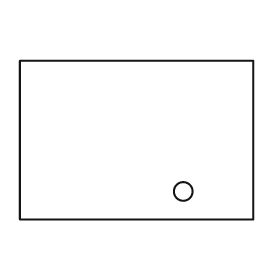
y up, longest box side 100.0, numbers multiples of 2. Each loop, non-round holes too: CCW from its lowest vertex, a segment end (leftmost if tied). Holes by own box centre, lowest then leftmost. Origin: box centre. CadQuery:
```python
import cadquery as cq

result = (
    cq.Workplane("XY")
    .moveTo(-50.0, -34.0)
    .lineTo(50.0, -34.0)
    .lineTo(50.0, 34.0)
    .lineTo(-50.0, 34.0)
    .close()
    .moveTo(20.0, -22.0)
    .circle(4.0)
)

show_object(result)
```